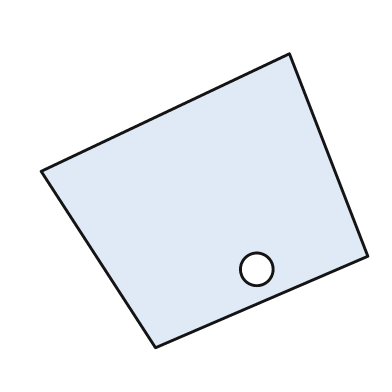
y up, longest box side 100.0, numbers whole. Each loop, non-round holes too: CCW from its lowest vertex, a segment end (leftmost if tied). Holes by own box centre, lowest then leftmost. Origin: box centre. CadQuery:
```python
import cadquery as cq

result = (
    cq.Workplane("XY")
    .moveTo(-15.0, -45.0)
    .lineTo(50.0, -17.0)
    .lineTo(26.0, 45.0)
    .lineTo(-50.0, 9.0)
    .close()
    .moveTo(16.0, -21.0)
    .circle(5.0)
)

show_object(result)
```